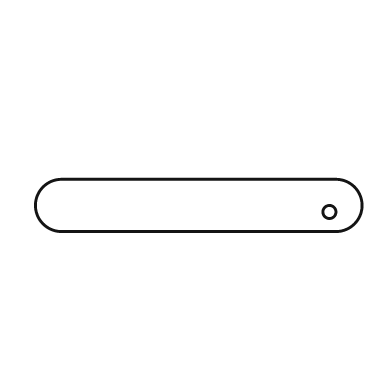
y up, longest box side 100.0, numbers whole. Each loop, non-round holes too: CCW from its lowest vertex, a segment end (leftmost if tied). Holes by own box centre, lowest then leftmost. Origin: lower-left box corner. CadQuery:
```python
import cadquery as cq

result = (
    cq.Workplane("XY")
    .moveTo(8.0, 0.0)
    .lineTo(92.0, 0.0)
    .threePointArc((100.0, 8.0), (92.0, 16.0))
    .lineTo(8.0, 16.0)
    .threePointArc((0.0, 8.0), (8.0, 0.0))
    .close()
    .moveTo(90.0, 6.0)
    .circle(2.0)
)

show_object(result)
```